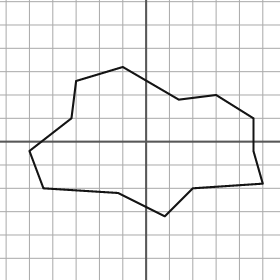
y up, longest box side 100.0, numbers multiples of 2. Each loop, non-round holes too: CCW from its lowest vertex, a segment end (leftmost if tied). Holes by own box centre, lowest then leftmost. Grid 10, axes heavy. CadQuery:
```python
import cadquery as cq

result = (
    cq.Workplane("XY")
    .moveTo(8.0, -32.0)
    .lineTo(20.0, -20.0)
    .lineTo(50.0, -18.0)
    .lineTo(46.0, -4.0)
    .lineTo(46.0, 10.0)
    .lineTo(30.0, 20.0)
    .lineTo(14.0, 18.0)
    .lineTo(-10.0, 32.0)
    .lineTo(-30.0, 26.0)
    .lineTo(-32.0, 10.0)
    .lineTo(-50.0, -4.0)
    .lineTo(-44.0, -20.0)
    .lineTo(-12.0, -22.0)
    .close()
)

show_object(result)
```